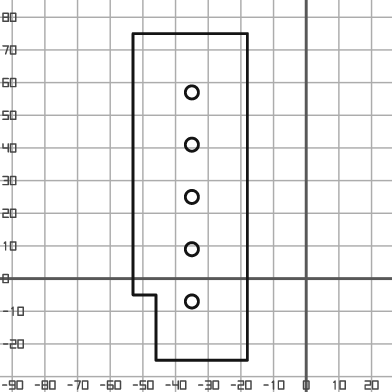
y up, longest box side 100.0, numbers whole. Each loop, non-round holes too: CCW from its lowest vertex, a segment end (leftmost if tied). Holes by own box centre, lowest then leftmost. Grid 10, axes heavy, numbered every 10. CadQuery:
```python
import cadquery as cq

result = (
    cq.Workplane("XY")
    .moveTo(-46.0, -25.0)
    .lineTo(-18.0, -25.0)
    .lineTo(-18.0, 75.0)
    .lineTo(-53.0, 75.0)
    .lineTo(-53.0, -5.0)
    .lineTo(-46.0, -5.0)
    .close()
    .moveTo(-35.0, -7.0)
    .circle(2.0)
    .moveTo(-35.0, 9.0)
    .circle(2.0)
    .moveTo(-35.0, 25.0)
    .circle(2.0)
    .moveTo(-35.0, 41.0)
    .circle(2.0)
    .moveTo(-35.0, 57.0)
    .circle(2.0)
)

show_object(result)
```